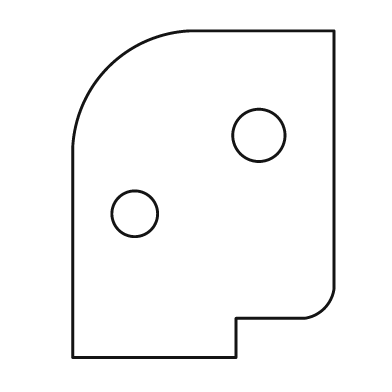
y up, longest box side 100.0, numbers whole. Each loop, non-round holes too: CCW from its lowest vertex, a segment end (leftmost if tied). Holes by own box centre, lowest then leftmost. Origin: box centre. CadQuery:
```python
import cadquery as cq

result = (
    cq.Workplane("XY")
    .moveTo(-40.0, -50.0)
    .lineTo(10.0, -50.0)
    .lineTo(10.0, -38.0)
    .lineTo(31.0, -38.0)
    .threePointArc((37.0, -35.0), (40.0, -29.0))
    .lineTo(40.0, 50.0)
    .lineTo(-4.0, 50.0)
    .threePointArc((-29.0, 39.0), (-40.0, 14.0))
    .close()
    .moveTo(-21.0, -6.0)
    .circle(7.0)
    .moveTo(17.0, 18.0)
    .circle(8.0)
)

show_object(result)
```